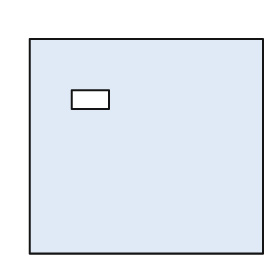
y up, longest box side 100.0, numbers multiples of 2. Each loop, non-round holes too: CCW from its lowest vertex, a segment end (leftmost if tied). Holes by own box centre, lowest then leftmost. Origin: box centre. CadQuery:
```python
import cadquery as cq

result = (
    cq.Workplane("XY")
    .moveTo(-50.0, -46.0)
    .lineTo(50.0, -46.0)
    .lineTo(50.0, 46.0)
    .lineTo(-50.0, 46.0)
    .close()
    .moveTo(-32.0, 16.0)
    .lineTo(-16.0, 16.0)
    .lineTo(-16.0, 24.0)
    .lineTo(-32.0, 24.0)
    .close()
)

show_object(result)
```